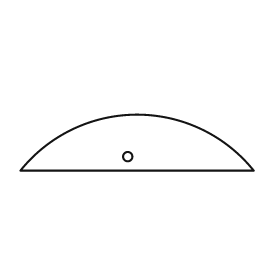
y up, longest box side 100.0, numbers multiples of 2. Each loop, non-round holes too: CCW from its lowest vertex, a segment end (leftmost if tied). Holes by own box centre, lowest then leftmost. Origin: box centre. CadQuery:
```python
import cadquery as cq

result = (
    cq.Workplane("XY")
    .moveTo(-50.0, -12.0)
    .lineTo(50.0, -12.0)
    .threePointArc((0.0, 12.0), (-50.0, -12.0))
    .close()
    .moveTo(-4.0, -6.0)
    .circle(2.0)
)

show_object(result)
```